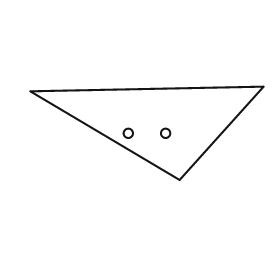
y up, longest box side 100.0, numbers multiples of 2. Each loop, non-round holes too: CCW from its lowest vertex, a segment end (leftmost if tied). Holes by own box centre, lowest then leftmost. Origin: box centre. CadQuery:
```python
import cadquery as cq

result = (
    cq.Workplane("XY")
    .moveTo(14.0, -20.0)
    .lineTo(50.0, 20.0)
    .lineTo(-50.0, 18.0)
    .close()
    .moveTo(-8.0, 0.0)
    .circle(2.0)
    .moveTo(8.0, 0.0)
    .circle(2.0)
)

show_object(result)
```